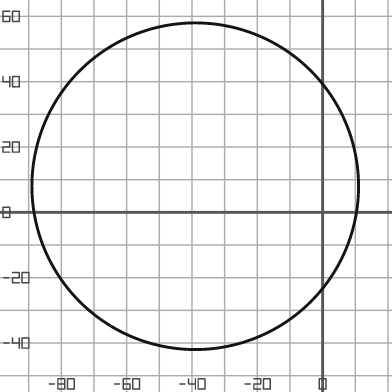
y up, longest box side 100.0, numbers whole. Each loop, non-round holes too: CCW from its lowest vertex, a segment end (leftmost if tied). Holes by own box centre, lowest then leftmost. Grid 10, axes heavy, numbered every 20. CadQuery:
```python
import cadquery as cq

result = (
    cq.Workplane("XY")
    .moveTo(-39.0, 8.0)
    .circle(50.0)
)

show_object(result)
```